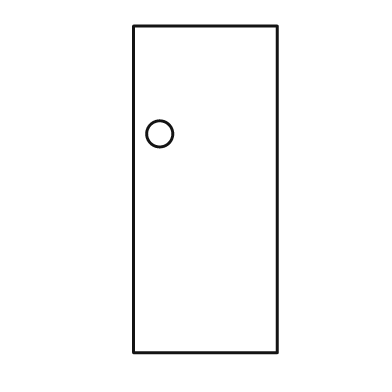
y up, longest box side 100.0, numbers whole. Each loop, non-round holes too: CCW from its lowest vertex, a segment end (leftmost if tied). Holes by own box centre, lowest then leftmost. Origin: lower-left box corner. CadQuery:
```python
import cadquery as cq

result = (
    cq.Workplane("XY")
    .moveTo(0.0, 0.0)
    .lineTo(44.0, 0.0)
    .lineTo(44.0, 100.0)
    .lineTo(0.0, 100.0)
    .close()
    .moveTo(8.0, 67.0)
    .circle(4.0)
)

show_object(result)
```